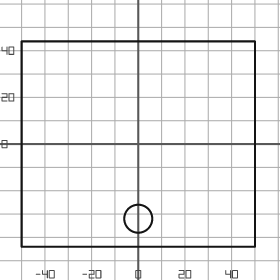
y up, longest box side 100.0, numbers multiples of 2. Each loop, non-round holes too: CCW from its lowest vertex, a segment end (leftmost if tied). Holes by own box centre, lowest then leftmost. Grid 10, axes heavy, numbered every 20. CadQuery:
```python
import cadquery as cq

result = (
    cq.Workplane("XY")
    .moveTo(-50.0, -44.0)
    .lineTo(50.0, -44.0)
    .lineTo(50.0, 44.0)
    .lineTo(-50.0, 44.0)
    .close()
    .moveTo(0.0, -32.0)
    .circle(6.0)
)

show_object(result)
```